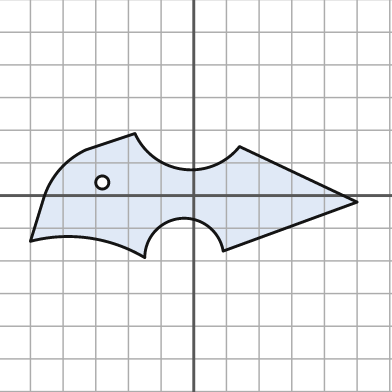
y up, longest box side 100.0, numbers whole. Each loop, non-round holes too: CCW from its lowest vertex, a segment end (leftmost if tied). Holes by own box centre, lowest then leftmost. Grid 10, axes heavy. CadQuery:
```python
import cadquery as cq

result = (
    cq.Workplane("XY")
    .moveTo(-15.0, -19.0)
    .threePointArc((-4.0, -7.0), (9.0, -17.0))
    .lineTo(50.0, -2.0)
    .lineTo(14.0, 15.0)
    .threePointArc((-3.0, 8.0), (-18.0, 19.0))
    .lineTo(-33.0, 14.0)
    .threePointArc((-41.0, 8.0), (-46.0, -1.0))
    .lineTo(-50.0, -14.0)
    .threePointArc((-32.0, -13.0), (-15.0, -19.0))
    .close()
    .moveTo(-28.0, 4.0)
    .circle(2.0)
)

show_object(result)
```